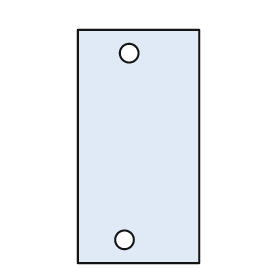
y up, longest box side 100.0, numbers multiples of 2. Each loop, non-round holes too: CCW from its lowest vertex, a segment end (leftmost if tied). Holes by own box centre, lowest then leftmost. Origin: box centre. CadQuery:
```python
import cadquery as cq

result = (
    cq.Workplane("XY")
    .moveTo(-26.0, -50.0)
    .lineTo(26.0, -50.0)
    .lineTo(26.0, 50.0)
    .lineTo(-26.0, 50.0)
    .close()
    .moveTo(-6.0, -40.0)
    .circle(4.0)
    .moveTo(-4.0, 40.0)
    .circle(4.0)
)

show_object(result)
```